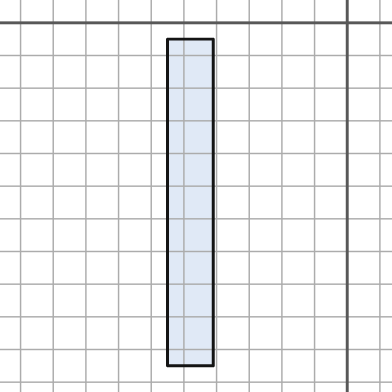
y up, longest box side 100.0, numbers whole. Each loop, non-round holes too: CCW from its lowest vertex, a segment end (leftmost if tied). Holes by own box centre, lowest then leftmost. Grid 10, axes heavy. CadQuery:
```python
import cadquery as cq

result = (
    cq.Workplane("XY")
    .moveTo(-55.0, -105.0)
    .lineTo(-41.0, -105.0)
    .lineTo(-41.0, -5.0)
    .lineTo(-55.0, -5.0)
    .close()
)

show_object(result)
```